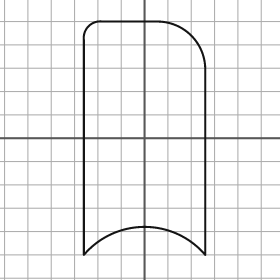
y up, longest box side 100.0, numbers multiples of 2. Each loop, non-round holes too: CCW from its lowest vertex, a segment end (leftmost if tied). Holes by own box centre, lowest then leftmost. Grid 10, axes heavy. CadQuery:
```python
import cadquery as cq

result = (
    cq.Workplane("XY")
    .moveTo(-26.0, -50.0)
    .threePointArc((0.0, -38.0), (26.0, -50.0))
    .lineTo(26.0, 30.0)
    .threePointArc((20.0, 44.0), (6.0, 50.0))
    .lineTo(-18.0, 50.0)
    .threePointArc((-24.0, 48.0), (-26.0, 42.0))
    .close()
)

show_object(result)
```